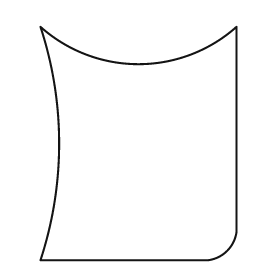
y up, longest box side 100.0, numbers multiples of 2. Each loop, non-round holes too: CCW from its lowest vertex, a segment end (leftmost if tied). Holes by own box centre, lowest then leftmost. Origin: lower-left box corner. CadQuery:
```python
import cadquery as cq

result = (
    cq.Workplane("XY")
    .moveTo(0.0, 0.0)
    .lineTo(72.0, 0.0)
    .threePointArc((80.0, 4.0), (84.0, 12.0))
    .lineTo(84.0, 100.0)
    .threePointArc((42.0, 84.0), (0.0, 100.0))
    .threePointArc((8.0, 50.0), (0.0, 0.0))
    .close()
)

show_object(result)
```